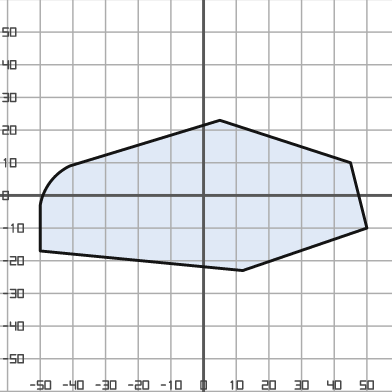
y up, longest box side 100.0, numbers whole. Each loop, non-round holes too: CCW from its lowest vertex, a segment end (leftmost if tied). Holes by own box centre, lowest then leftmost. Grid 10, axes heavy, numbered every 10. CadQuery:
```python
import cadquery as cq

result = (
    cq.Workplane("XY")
    .moveTo(12.0, -23.0)
    .lineTo(50.0, -10.0)
    .lineTo(45.0, 10.0)
    .lineTo(5.0, 23.0)
    .lineTo(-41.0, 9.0)
    .threePointArc((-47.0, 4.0), (-50.0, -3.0))
    .lineTo(-50.0, -17.0)
    .close()
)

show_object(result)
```